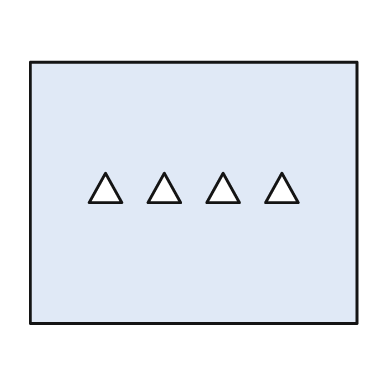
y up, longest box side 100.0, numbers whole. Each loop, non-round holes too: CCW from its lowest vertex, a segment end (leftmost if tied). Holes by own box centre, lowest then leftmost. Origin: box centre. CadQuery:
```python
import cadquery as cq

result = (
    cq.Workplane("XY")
    .moveTo(-50.0, -40.0)
    .lineTo(50.0, -40.0)
    .lineTo(50.0, 40.0)
    .lineTo(-50.0, 40.0)
    .close()
    .moveTo(-32.0, -3.0)
    .lineTo(-22.0, -3.0)
    .lineTo(-27.0, 6.0)
    .close()
    .moveTo(-14.0, -3.0)
    .lineTo(-4.0, -3.0)
    .lineTo(-9.0, 6.0)
    .close()
    .moveTo(4.0, -3.0)
    .lineTo(14.0, -3.0)
    .lineTo(9.0, 6.0)
    .close()
    .moveTo(22.0, -3.0)
    .lineTo(32.0, -3.0)
    .lineTo(27.0, 6.0)
    .close()
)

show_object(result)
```